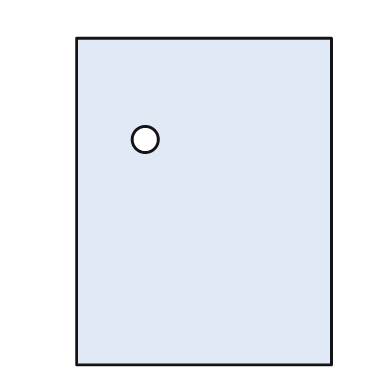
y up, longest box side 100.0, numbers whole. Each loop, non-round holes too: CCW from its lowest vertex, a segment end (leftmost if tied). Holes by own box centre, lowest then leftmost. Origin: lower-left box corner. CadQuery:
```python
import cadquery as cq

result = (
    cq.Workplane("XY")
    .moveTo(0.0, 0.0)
    .lineTo(78.0, 0.0)
    .lineTo(78.0, 100.0)
    .lineTo(0.0, 100.0)
    .close()
    .moveTo(21.0, 69.0)
    .circle(4.0)
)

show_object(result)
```